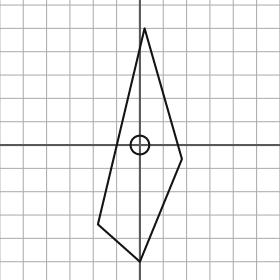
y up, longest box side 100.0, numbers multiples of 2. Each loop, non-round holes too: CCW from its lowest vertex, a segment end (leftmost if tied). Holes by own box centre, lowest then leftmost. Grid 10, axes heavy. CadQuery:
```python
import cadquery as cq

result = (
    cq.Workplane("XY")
    .moveTo(0.0, -50.0)
    .lineTo(18.0, -6.0)
    .lineTo(2.0, 50.0)
    .lineTo(-18.0, -34.0)
    .close()
    .moveTo(0.0, 0.0)
    .circle(4.0)
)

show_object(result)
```